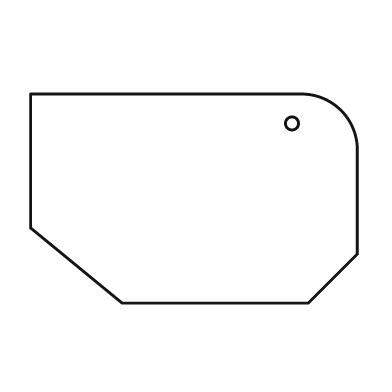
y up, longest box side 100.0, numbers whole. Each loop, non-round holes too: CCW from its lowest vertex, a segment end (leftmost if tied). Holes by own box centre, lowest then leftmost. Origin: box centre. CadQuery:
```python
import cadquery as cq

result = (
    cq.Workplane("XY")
    .moveTo(-22.0, -32.0)
    .lineTo(35.0, -32.0)
    .lineTo(50.0, -17.0)
    .lineTo(50.0, 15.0)
    .threePointArc((45.0, 27.0), (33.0, 32.0))
    .lineTo(-50.0, 32.0)
    .lineTo(-50.0, -9.0)
    .close()
    .moveTo(30.0, 23.0)
    .circle(2.0)
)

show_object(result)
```